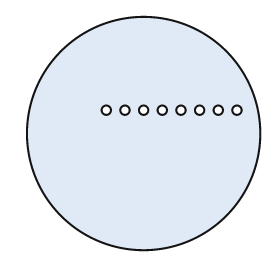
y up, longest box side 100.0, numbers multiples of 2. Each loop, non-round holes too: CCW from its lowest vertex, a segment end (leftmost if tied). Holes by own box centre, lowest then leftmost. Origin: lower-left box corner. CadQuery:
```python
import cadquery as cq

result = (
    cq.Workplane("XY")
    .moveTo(50.0, 50.0)
    .circle(50.0)
    .moveTo(34.0, 60.0)
    .circle(2.0)
    .moveTo(42.0, 60.0)
    .circle(2.0)
    .moveTo(50.0, 60.0)
    .circle(2.0)
    .moveTo(58.0, 60.0)
    .circle(2.0)
    .moveTo(66.0, 60.0)
    .circle(2.0)
    .moveTo(74.0, 60.0)
    .circle(2.0)
    .moveTo(82.0, 60.0)
    .circle(2.0)
    .moveTo(90.0, 60.0)
    .circle(2.0)
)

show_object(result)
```